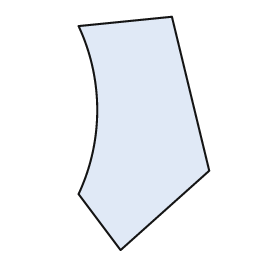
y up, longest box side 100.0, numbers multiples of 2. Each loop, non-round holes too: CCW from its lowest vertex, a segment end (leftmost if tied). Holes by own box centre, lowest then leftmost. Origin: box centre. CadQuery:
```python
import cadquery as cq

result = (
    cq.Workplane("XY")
    .moveTo(-10.0, -50.0)
    .lineTo(28.0, -16.0)
    .lineTo(12.0, 50.0)
    .lineTo(-28.0, 46.0)
    .threePointArc((-20.0, 10.0), (-28.0, -26.0))
    .close()
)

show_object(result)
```